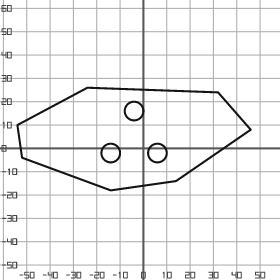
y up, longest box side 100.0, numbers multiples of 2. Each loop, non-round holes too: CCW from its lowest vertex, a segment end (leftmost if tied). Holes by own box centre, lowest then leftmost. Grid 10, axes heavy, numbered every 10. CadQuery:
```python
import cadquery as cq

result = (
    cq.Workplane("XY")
    .moveTo(-14.0, -18.0)
    .lineTo(14.0, -14.0)
    .lineTo(46.0, 8.0)
    .lineTo(32.0, 24.0)
    .lineTo(-24.0, 26.0)
    .lineTo(-54.0, 10.0)
    .lineTo(-52.0, -4.0)
    .close()
    .moveTo(-14.0, -2.0)
    .circle(4.0)
    .moveTo(6.0, -2.0)
    .circle(4.0)
    .moveTo(-4.0, 16.0)
    .circle(4.0)
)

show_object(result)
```